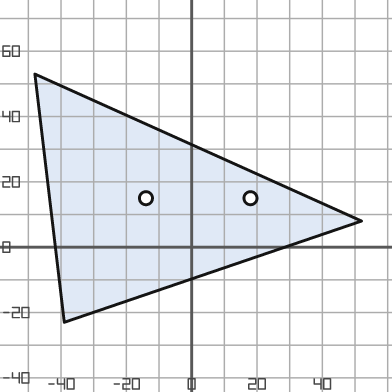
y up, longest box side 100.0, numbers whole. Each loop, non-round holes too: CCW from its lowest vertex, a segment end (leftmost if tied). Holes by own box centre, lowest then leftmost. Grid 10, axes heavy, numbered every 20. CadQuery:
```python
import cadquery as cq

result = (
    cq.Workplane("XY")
    .moveTo(-39.0, -23.0)
    .lineTo(52.0, 8.0)
    .lineTo(-48.0, 53.0)
    .close()
    .moveTo(-14.0, 15.0)
    .circle(2.0)
    .moveTo(18.0, 15.0)
    .circle(2.0)
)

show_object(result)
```